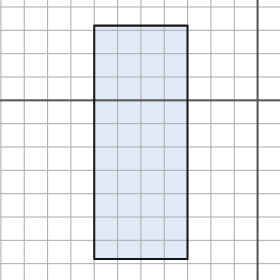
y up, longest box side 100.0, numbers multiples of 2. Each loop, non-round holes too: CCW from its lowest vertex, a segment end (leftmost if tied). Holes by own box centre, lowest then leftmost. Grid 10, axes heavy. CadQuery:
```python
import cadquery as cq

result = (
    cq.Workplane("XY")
    .moveTo(-70.0, -68.0)
    .lineTo(-30.0, -68.0)
    .lineTo(-30.0, 32.0)
    .lineTo(-70.0, 32.0)
    .close()
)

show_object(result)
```